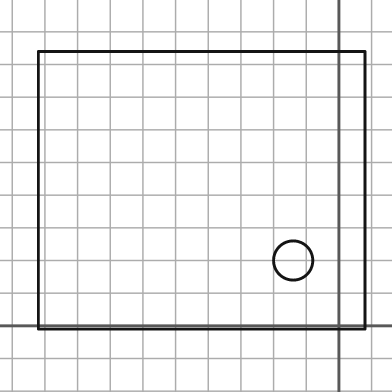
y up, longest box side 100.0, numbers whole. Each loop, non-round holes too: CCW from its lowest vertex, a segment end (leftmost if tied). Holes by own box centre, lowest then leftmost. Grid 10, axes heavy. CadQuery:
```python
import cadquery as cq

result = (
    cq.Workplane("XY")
    .moveTo(-92.0, -1.0)
    .lineTo(8.0, -1.0)
    .lineTo(8.0, 84.0)
    .lineTo(-92.0, 84.0)
    .close()
    .moveTo(-14.0, 20.0)
    .circle(6.0)
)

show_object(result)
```